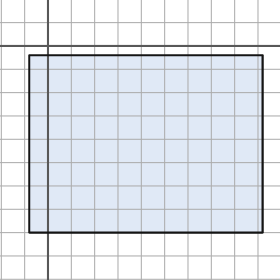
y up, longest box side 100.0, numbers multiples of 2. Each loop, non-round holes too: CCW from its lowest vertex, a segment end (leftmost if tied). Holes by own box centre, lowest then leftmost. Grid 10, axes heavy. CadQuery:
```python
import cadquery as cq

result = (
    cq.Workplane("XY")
    .moveTo(-8.0, -80.0)
    .lineTo(92.0, -80.0)
    .lineTo(92.0, -4.0)
    .lineTo(-8.0, -4.0)
    .close()
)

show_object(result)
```